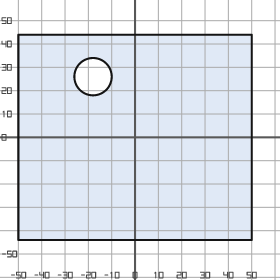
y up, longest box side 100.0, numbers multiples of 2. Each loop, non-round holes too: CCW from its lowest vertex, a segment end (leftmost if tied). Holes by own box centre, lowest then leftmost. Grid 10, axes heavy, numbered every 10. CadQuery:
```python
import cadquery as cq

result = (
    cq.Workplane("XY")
    .moveTo(-50.0, -44.0)
    .lineTo(50.0, -44.0)
    .lineTo(50.0, 44.0)
    .lineTo(-50.0, 44.0)
    .close()
    .moveTo(-18.0, 26.0)
    .circle(8.0)
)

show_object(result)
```